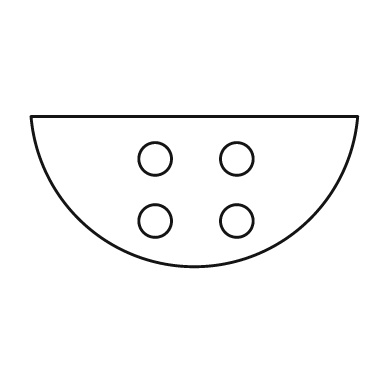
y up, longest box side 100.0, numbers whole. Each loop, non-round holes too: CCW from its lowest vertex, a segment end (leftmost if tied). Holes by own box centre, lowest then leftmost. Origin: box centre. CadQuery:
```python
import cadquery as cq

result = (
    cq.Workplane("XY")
    .moveTo(-50.0, 23.0)
    .threePointArc((0.0, -23.0), (50.0, 23.0))
    .close()
    .moveTo(-12.0, -9.0)
    .circle(5.0)
    .moveTo(13.0, -9.0)
    .circle(5.0)
    .moveTo(-12.0, 10.0)
    .circle(5.0)
    .moveTo(13.0, 10.0)
    .circle(5.0)
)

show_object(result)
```